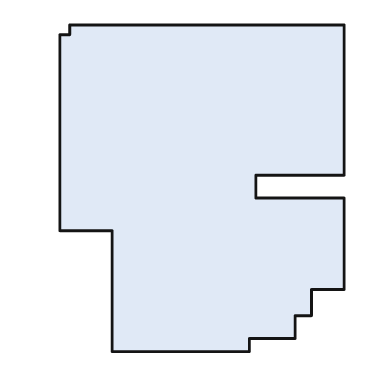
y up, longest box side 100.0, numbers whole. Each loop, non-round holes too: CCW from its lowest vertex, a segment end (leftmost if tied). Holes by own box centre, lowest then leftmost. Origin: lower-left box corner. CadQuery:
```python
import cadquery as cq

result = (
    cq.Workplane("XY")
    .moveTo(16.0, 0.0)
    .lineTo(58.0, 0.0)
    .lineTo(58.0, 4.0)
    .lineTo(72.0, 4.0)
    .lineTo(72.0, 11.0)
    .lineTo(77.0, 11.0)
    .lineTo(77.0, 19.0)
    .lineTo(87.0, 19.0)
    .lineTo(87.0, 47.0)
    .lineTo(60.0, 47.0)
    .lineTo(60.0, 54.0)
    .lineTo(87.0, 54.0)
    .lineTo(87.0, 100.0)
    .lineTo(3.0, 100.0)
    .lineTo(3.0, 97.0)
    .lineTo(0.0, 97.0)
    .lineTo(0.0, 37.0)
    .lineTo(16.0, 37.0)
    .close()
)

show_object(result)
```